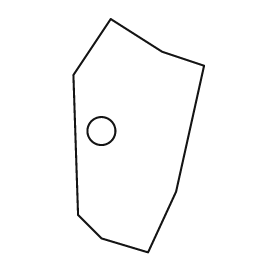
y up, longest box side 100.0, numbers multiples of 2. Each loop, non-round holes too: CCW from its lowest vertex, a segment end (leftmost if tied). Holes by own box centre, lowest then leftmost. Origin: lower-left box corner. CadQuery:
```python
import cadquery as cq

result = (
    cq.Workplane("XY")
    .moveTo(32.0, 0.0)
    .lineTo(44.0, 26.0)
    .lineTo(56.0, 80.0)
    .lineTo(38.0, 86.0)
    .lineTo(16.0, 100.0)
    .lineTo(0.0, 76.0)
    .lineTo(2.0, 16.0)
    .lineTo(12.0, 6.0)
    .close()
    .moveTo(12.0, 52.0)
    .circle(6.0)
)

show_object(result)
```